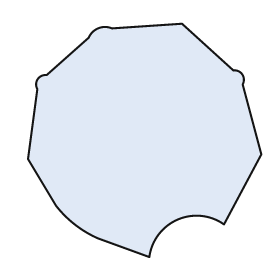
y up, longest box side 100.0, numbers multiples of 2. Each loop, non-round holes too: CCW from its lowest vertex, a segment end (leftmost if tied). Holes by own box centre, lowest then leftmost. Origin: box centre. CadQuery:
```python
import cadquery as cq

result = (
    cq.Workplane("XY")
    .moveTo(2.0, -50.0)
    .threePointArc((14.0, -34.0), (34.0, -36.0))
    .lineTo(50.0, -6.0)
    .lineTo(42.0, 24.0)
    .threePointArc((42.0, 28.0), (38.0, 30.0))
    .lineTo(16.0, 50.0)
    .lineTo(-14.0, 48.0)
    .threePointArc((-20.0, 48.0), (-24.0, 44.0))
    .lineTo(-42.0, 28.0)
    .threePointArc((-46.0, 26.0), (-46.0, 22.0))
    .lineTo(-50.0, -8.0)
    .lineTo(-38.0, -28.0)
    .threePointArc((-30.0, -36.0), (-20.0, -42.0))
    .close()
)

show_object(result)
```